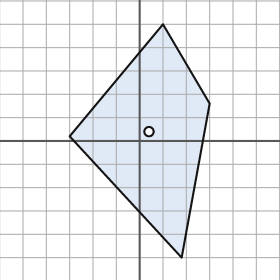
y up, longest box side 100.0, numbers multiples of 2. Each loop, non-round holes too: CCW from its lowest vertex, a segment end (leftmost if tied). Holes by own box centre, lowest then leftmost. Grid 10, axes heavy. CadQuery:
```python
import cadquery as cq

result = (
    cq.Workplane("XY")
    .moveTo(18.0, -50.0)
    .lineTo(30.0, 16.0)
    .lineTo(10.0, 50.0)
    .lineTo(-30.0, 2.0)
    .close()
    .moveTo(4.0, 4.0)
    .circle(2.0)
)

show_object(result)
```